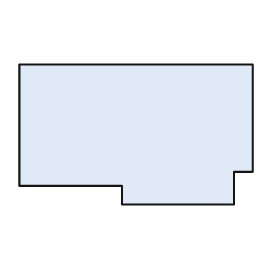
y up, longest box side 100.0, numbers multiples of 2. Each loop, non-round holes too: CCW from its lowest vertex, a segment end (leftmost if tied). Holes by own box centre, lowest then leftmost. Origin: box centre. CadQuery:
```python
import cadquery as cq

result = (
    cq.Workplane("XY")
    .moveTo(-6.0, -30.0)
    .lineTo(42.0, -30.0)
    .lineTo(42.0, -16.0)
    .lineTo(50.0, -16.0)
    .lineTo(50.0, 30.0)
    .lineTo(-50.0, 30.0)
    .lineTo(-50.0, -22.0)
    .lineTo(-6.0, -22.0)
    .close()
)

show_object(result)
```